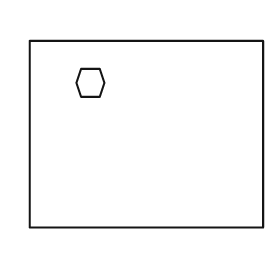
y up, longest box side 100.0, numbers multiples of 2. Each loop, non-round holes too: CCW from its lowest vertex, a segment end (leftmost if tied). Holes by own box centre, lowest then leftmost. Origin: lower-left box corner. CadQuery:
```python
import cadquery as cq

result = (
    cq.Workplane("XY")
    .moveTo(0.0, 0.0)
    .lineTo(100.0, 0.0)
    .lineTo(100.0, 80.0)
    .lineTo(0.0, 80.0)
    .close()
    .moveTo(22.0, 56.0)
    .lineTo(30.0, 56.0)
    .lineTo(32.0, 62.0)
    .lineTo(30.0, 68.0)
    .lineTo(22.0, 68.0)
    .lineTo(20.0, 62.0)
    .close()
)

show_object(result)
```